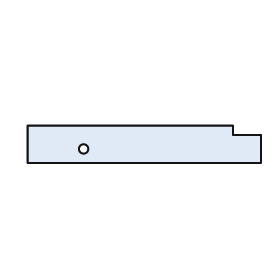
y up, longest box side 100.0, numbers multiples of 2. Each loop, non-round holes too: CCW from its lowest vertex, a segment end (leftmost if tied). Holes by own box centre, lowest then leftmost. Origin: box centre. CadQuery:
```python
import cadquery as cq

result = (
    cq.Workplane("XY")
    .moveTo(-50.0, -8.0)
    .lineTo(50.0, -8.0)
    .lineTo(50.0, 4.0)
    .lineTo(38.0, 4.0)
    .lineTo(38.0, 8.0)
    .lineTo(-50.0, 8.0)
    .close()
    .moveTo(-26.0, -2.0)
    .circle(2.0)
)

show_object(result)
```